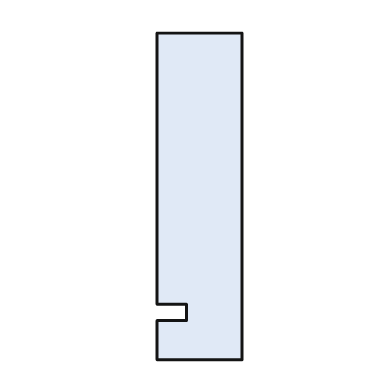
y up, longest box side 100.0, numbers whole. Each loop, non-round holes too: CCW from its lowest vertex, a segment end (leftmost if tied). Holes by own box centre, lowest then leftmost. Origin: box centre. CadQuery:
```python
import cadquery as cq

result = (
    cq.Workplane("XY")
    .moveTo(-13.0, -50.0)
    .lineTo(13.0, -50.0)
    .lineTo(13.0, 50.0)
    .lineTo(-13.0, 50.0)
    .lineTo(-13.0, -33.0)
    .lineTo(-4.0, -33.0)
    .lineTo(-4.0, -38.0)
    .lineTo(-13.0, -38.0)
    .close()
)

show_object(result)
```